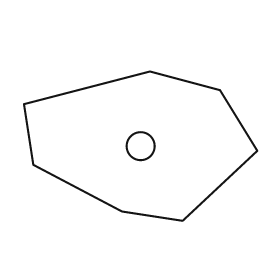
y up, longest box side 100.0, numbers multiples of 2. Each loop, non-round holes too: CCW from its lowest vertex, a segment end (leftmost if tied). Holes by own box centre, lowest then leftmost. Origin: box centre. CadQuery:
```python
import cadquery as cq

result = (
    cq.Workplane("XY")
    .moveTo(18.0, -32.0)
    .lineTo(50.0, -2.0)
    .lineTo(34.0, 24.0)
    .lineTo(4.0, 32.0)
    .lineTo(-50.0, 18.0)
    .lineTo(-46.0, -8.0)
    .lineTo(-8.0, -28.0)
    .close()
    .moveTo(0.0, 0.0)
    .circle(6.0)
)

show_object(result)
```